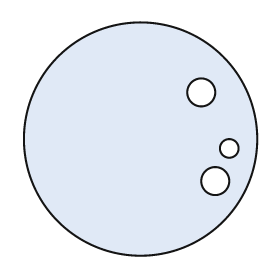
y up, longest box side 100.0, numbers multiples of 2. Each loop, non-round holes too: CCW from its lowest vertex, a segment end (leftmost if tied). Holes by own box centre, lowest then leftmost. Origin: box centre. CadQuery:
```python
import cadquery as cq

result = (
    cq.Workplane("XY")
    .moveTo(0.0, 0.0)
    .circle(50.0)
    .moveTo(32.0, -18.0)
    .circle(6.0)
    .moveTo(38.0, -4.0)
    .circle(4.0)
    .moveTo(26.0, 20.0)
    .circle(6.0)
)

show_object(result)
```